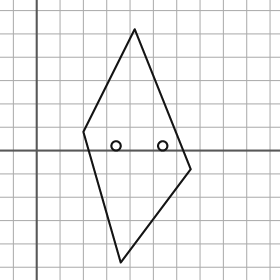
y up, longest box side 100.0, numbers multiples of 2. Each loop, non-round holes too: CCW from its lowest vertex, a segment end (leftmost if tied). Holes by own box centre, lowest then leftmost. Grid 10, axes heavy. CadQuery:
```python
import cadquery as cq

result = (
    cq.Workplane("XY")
    .moveTo(36.0, -48.0)
    .lineTo(66.0, -8.0)
    .lineTo(42.0, 52.0)
    .lineTo(20.0, 8.0)
    .close()
    .moveTo(34.0, 2.0)
    .circle(2.0)
    .moveTo(54.0, 2.0)
    .circle(2.0)
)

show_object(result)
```